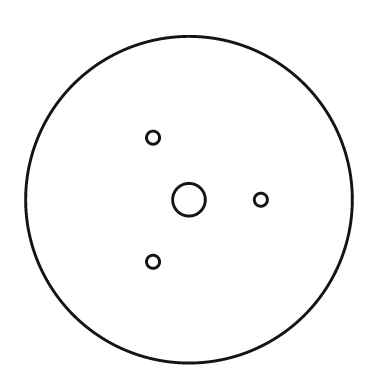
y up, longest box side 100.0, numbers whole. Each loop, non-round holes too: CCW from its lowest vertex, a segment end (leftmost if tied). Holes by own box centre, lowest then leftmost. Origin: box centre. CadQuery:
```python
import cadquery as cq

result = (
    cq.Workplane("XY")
    .moveTo(0.0, 0.0)
    .circle(50.0)
    .moveTo(-11.0, -19.0)
    .circle(2.0)
    .moveTo(0.0, 0.0)
    .circle(5.0)
    .moveTo(22.0, 0.0)
    .circle(2.0)
    .moveTo(-11.0, 19.0)
    .circle(2.0)
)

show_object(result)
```